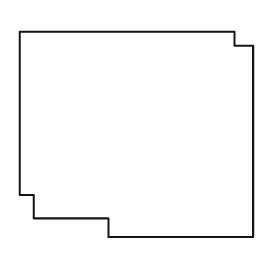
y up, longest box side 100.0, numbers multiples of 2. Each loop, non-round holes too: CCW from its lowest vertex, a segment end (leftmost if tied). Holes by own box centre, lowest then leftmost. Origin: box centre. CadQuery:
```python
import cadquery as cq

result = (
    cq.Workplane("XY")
    .moveTo(-12.0, -44.0)
    .lineTo(50.0, -44.0)
    .lineTo(50.0, 38.0)
    .lineTo(42.0, 38.0)
    .lineTo(42.0, 44.0)
    .lineTo(-50.0, 44.0)
    .lineTo(-50.0, -26.0)
    .lineTo(-44.0, -26.0)
    .lineTo(-44.0, -36.0)
    .lineTo(-12.0, -36.0)
    .close()
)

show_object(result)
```